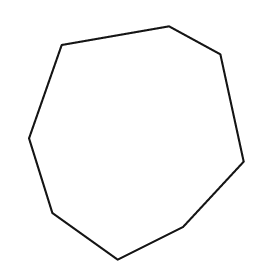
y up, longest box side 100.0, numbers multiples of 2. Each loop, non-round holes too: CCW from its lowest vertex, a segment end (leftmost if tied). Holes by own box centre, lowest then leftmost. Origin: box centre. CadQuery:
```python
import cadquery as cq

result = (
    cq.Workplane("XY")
    .moveTo(-8.0, -50.0)
    .lineTo(20.0, -36.0)
    .lineTo(46.0, -8.0)
    .lineTo(36.0, 38.0)
    .lineTo(14.0, 50.0)
    .lineTo(-32.0, 42.0)
    .lineTo(-46.0, 2.0)
    .lineTo(-36.0, -30.0)
    .close()
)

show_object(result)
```